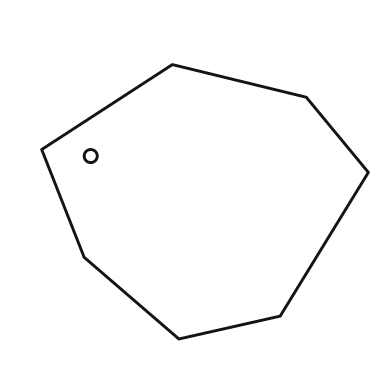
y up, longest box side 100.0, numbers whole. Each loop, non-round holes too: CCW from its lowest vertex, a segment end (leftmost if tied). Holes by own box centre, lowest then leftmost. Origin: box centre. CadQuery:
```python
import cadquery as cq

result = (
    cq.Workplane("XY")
    .moveTo(-8.0, -42.0)
    .lineTo(23.0, -35.0)
    .lineTo(50.0, 9.0)
    .lineTo(31.0, 32.0)
    .lineTo(-10.0, 42.0)
    .lineTo(-50.0, 16.0)
    .lineTo(-37.0, -17.0)
    .close()
    .moveTo(-35.0, 14.0)
    .circle(2.0)
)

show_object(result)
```